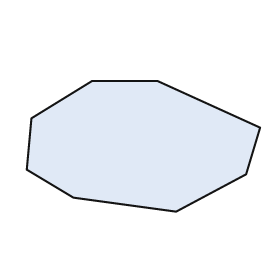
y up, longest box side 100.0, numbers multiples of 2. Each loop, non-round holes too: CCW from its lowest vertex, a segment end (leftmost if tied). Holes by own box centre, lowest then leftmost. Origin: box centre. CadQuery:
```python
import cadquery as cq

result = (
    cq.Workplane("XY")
    .moveTo(14.0, -28.0)
    .lineTo(44.0, -12.0)
    .lineTo(50.0, 8.0)
    .lineTo(6.0, 28.0)
    .lineTo(-22.0, 28.0)
    .lineTo(-48.0, 12.0)
    .lineTo(-50.0, -10.0)
    .lineTo(-30.0, -22.0)
    .close()
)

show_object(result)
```